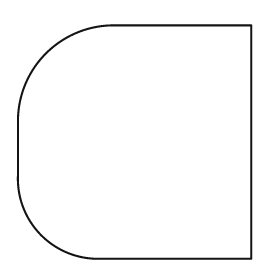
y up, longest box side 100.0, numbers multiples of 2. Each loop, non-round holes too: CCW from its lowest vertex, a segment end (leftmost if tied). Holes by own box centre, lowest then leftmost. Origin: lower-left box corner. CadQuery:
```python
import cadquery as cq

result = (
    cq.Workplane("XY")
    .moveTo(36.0, 0.0)
    .lineTo(100.0, 0.0)
    .lineTo(100.0, 100.0)
    .lineTo(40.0, 100.0)
    .threePointArc((12.0, 88.0), (0.0, 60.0))
    .lineTo(0.0, 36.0)
    .threePointArc((10.0, 10.0), (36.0, 0.0))
    .close()
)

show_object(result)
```